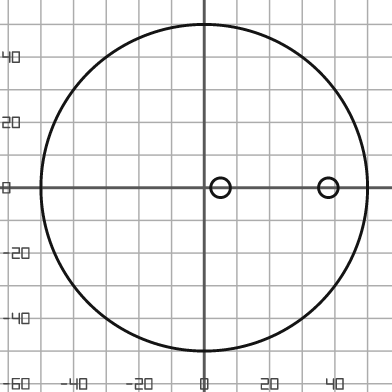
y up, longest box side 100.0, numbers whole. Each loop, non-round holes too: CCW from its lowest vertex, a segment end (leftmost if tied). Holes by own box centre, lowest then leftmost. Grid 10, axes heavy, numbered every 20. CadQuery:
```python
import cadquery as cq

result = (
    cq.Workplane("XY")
    .moveTo(0.0, 0.0)
    .circle(50.0)
    .moveTo(5.0, 0.0)
    .circle(3.0)
    .moveTo(38.0, 0.0)
    .circle(3.0)
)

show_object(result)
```